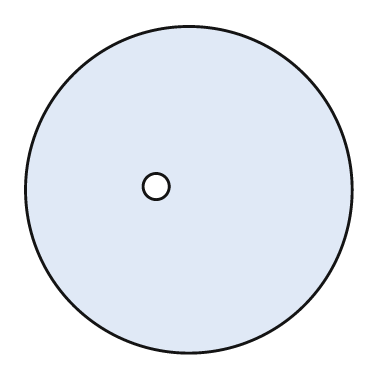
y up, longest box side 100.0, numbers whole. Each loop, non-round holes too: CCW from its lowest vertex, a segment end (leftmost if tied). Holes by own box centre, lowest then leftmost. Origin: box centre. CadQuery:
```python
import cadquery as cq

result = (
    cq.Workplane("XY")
    .moveTo(0.0, 0.0)
    .circle(50.0)
    .moveTo(-10.0, 1.0)
    .circle(4.0)
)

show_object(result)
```